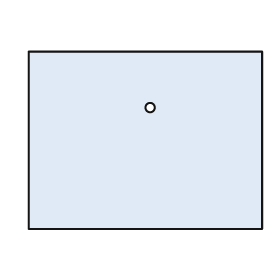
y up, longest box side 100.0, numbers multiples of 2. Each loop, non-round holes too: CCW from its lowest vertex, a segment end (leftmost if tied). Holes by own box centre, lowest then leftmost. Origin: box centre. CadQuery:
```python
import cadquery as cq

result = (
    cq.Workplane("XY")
    .moveTo(-50.0, -38.0)
    .lineTo(50.0, -38.0)
    .lineTo(50.0, 38.0)
    .lineTo(-50.0, 38.0)
    .close()
    .moveTo(2.0, 14.0)
    .circle(2.0)
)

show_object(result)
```